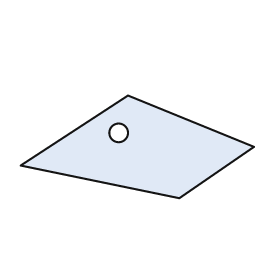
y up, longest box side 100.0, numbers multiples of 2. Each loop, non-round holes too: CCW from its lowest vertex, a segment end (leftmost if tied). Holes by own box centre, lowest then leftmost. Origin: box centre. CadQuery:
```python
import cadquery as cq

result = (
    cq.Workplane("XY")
    .moveTo(18.0, -22.0)
    .lineTo(50.0, 0.0)
    .lineTo(-4.0, 22.0)
    .lineTo(-50.0, -8.0)
    .close()
    .moveTo(-8.0, 6.0)
    .circle(4.0)
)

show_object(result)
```